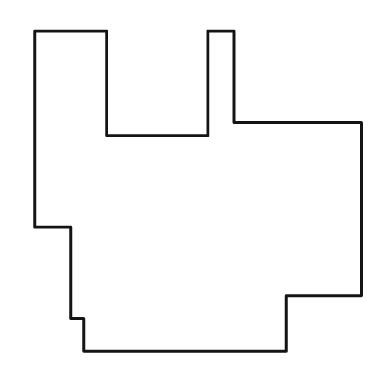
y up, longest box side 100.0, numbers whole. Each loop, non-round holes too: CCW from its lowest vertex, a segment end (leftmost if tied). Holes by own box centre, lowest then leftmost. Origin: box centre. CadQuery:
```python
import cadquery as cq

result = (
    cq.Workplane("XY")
    .moveTo(-35.0, -49.0)
    .lineTo(27.0, -49.0)
    .lineTo(27.0, -32.0)
    .lineTo(50.0, -32.0)
    .lineTo(50.0, 21.0)
    .lineTo(11.0, 21.0)
    .lineTo(11.0, 49.0)
    .lineTo(3.0, 49.0)
    .lineTo(3.0, 17.0)
    .lineTo(-28.0, 17.0)
    .lineTo(-28.0, 49.0)
    .lineTo(-50.0, 49.0)
    .lineTo(-50.0, -11.0)
    .lineTo(-39.0, -11.0)
    .lineTo(-39.0, -39.0)
    .lineTo(-35.0, -39.0)
    .close()
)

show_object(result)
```